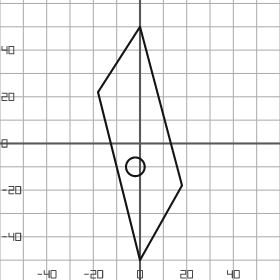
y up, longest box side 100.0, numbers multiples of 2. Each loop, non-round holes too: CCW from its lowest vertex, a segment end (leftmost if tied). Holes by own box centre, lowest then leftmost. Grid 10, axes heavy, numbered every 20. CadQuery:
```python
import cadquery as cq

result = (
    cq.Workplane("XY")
    .moveTo(0.0, -50.0)
    .lineTo(18.0, -18.0)
    .lineTo(0.0, 50.0)
    .lineTo(-18.0, 22.0)
    .close()
    .moveTo(-2.0, -10.0)
    .circle(4.0)
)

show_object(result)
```